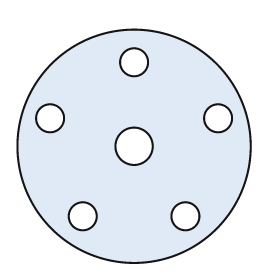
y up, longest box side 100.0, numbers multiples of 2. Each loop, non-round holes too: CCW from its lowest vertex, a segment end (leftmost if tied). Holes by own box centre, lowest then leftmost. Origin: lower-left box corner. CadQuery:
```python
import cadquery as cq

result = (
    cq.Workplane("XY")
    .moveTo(50.0, 50.0)
    .circle(50.0)
    .moveTo(28.0, 20.0)
    .circle(6.0)
    .moveTo(72.0, 20.0)
    .circle(6.0)
    .moveTo(50.0, 50.0)
    .circle(8.0)
    .moveTo(14.0, 62.0)
    .circle(6.0)
    .moveTo(86.0, 62.0)
    .circle(6.0)
    .moveTo(50.0, 86.0)
    .circle(6.0)
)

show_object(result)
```